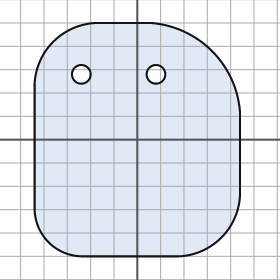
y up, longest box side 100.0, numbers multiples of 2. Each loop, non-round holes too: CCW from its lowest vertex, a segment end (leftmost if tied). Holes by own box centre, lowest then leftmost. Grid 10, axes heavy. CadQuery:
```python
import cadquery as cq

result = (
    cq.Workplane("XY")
    .moveTo(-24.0, -50.0)
    .lineTo(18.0, -50.0)
    .threePointArc((36.0, -42.0), (44.0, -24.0))
    .lineTo(44.0, 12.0)
    .threePointArc((32.0, 38.0), (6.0, 50.0))
    .lineTo(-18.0, 50.0)
    .threePointArc((-36.0, 42.0), (-44.0, 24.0))
    .lineTo(-44.0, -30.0)
    .threePointArc((-38.0, -44.0), (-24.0, -50.0))
    .close()
    .moveTo(-24.0, 28.0)
    .circle(4.0)
    .moveTo(8.0, 28.0)
    .circle(4.0)
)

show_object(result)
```